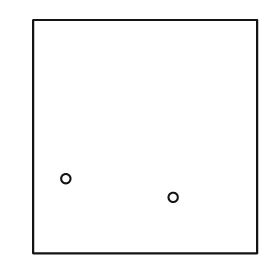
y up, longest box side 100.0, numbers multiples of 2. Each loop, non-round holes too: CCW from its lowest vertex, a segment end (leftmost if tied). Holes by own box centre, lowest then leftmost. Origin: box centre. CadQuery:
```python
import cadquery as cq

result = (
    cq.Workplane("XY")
    .moveTo(-48.0, -50.0)
    .lineTo(48.0, -50.0)
    .lineTo(48.0, 50.0)
    .lineTo(-48.0, 50.0)
    .close()
    .moveTo(12.0, -26.0)
    .circle(2.0)
    .moveTo(-34.0, -18.0)
    .circle(2.0)
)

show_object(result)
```